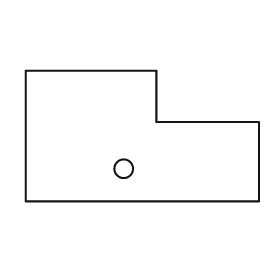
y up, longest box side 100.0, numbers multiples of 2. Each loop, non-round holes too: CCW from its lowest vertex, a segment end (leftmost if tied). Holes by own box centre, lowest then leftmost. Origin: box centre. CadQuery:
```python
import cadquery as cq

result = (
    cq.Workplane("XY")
    .moveTo(-50.0, -28.0)
    .lineTo(50.0, -28.0)
    .lineTo(50.0, 6.0)
    .lineTo(6.0, 6.0)
    .lineTo(6.0, 28.0)
    .lineTo(-50.0, 28.0)
    .close()
    .moveTo(-8.0, -14.0)
    .circle(4.0)
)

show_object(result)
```